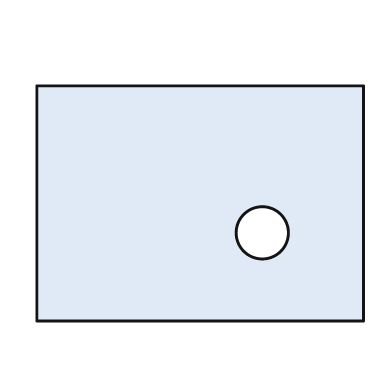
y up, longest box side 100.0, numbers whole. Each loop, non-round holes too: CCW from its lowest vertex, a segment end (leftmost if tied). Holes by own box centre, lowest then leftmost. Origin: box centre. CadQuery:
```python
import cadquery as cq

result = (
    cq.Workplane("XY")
    .moveTo(-50.0, -36.0)
    .lineTo(50.0, -36.0)
    .lineTo(50.0, 36.0)
    .lineTo(-50.0, 36.0)
    .close()
    .moveTo(19.0, -9.0)
    .circle(8.0)
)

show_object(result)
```